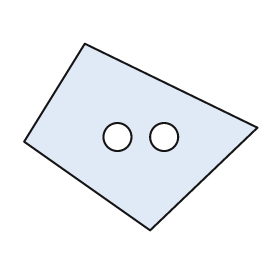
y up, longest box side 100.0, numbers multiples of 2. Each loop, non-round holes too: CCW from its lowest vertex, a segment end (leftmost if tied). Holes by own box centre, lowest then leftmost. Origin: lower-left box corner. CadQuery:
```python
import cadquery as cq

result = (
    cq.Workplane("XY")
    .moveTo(54.0, 0.0)
    .lineTo(100.0, 44.0)
    .lineTo(26.0, 80.0)
    .lineTo(0.0, 38.0)
    .close()
    .moveTo(40.0, 40.0)
    .circle(6.0)
    .moveTo(60.0, 40.0)
    .circle(6.0)
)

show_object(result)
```